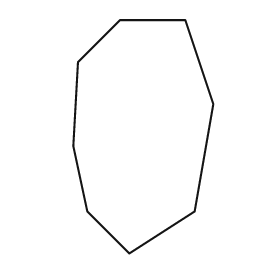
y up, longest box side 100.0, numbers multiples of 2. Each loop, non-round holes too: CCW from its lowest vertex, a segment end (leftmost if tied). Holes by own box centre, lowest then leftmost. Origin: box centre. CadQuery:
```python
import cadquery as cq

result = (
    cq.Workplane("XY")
    .moveTo(-6.0, -50.0)
    .lineTo(22.0, -32.0)
    .lineTo(30.0, 14.0)
    .lineTo(18.0, 50.0)
    .lineTo(-10.0, 50.0)
    .lineTo(-28.0, 32.0)
    .lineTo(-30.0, -4.0)
    .lineTo(-24.0, -32.0)
    .close()
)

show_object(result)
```